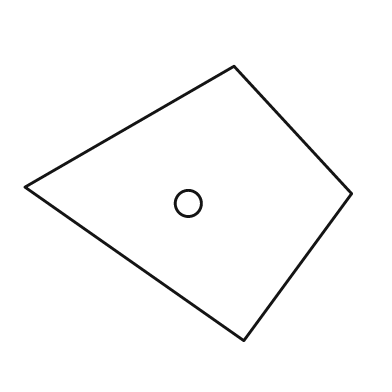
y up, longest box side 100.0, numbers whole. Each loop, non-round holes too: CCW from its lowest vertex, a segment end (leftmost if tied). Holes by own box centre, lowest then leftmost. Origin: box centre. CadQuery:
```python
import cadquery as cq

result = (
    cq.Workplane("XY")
    .moveTo(17.0, -42.0)
    .lineTo(50.0, 3.0)
    .lineTo(14.0, 42.0)
    .lineTo(-50.0, 5.0)
    .close()
    .moveTo(0.0, 0.0)
    .circle(4.0)
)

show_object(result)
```